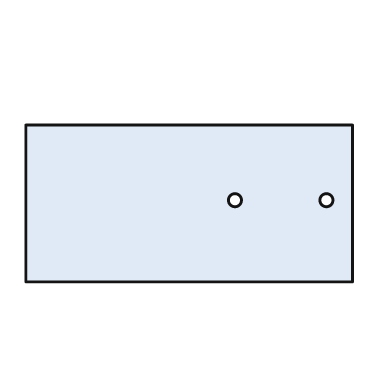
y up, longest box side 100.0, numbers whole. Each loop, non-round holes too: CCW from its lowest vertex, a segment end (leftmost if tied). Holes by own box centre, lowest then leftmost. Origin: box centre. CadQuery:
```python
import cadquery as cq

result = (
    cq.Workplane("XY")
    .moveTo(-50.0, -24.0)
    .lineTo(50.0, -24.0)
    .lineTo(50.0, 24.0)
    .lineTo(-50.0, 24.0)
    .close()
    .moveTo(14.0, 1.0)
    .circle(2.0)
    .moveTo(42.0, 1.0)
    .circle(2.0)
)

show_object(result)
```